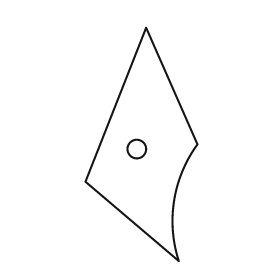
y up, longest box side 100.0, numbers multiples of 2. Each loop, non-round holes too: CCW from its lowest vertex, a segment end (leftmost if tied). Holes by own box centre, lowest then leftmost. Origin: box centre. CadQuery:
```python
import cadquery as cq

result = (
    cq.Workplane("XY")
    .moveTo(16.0, -50.0)
    .threePointArc((14.0, -24.0), (24.0, 0.0))
    .lineTo(2.0, 50.0)
    .lineTo(-24.0, -16.0)
    .close()
    .moveTo(-2.0, -2.0)
    .circle(4.0)
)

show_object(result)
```